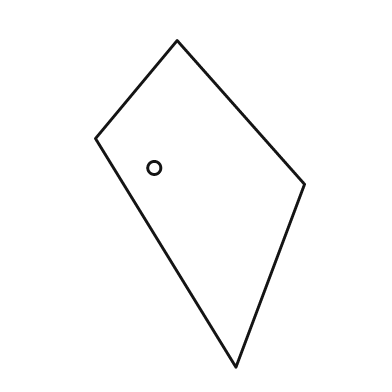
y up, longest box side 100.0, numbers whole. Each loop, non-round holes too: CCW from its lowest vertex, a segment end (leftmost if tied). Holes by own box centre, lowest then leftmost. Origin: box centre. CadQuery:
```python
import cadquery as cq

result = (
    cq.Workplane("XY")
    .moveTo(11.0, -50.0)
    .lineTo(32.0, 6.0)
    .lineTo(-7.0, 50.0)
    .lineTo(-32.0, 20.0)
    .close()
    .moveTo(-14.0, 11.0)
    .circle(2.0)
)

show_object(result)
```